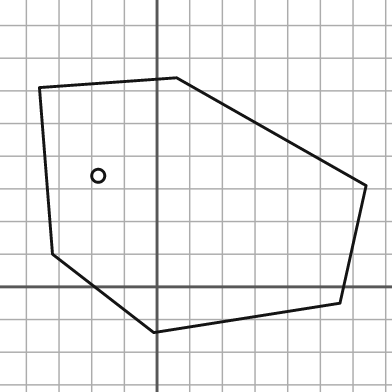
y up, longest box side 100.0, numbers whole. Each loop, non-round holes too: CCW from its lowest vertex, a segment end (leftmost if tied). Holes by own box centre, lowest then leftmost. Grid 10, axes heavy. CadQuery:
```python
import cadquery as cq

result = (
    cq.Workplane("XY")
    .moveTo(-1.0, -14.0)
    .lineTo(56.0, -5.0)
    .lineTo(64.0, 31.0)
    .lineTo(6.0, 64.0)
    .lineTo(-36.0, 61.0)
    .lineTo(-32.0, 10.0)
    .close()
    .moveTo(-18.0, 34.0)
    .circle(2.0)
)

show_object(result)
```